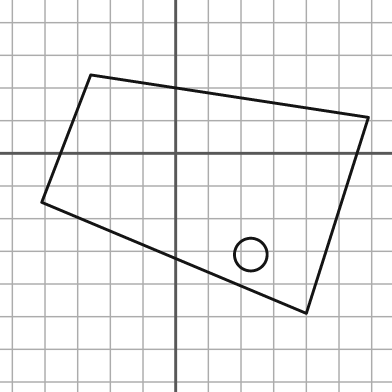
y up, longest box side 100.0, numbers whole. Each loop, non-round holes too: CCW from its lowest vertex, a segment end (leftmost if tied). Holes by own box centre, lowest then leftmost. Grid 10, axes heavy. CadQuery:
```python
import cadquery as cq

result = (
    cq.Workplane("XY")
    .moveTo(40.0, -49.0)
    .lineTo(59.0, 11.0)
    .lineTo(-26.0, 24.0)
    .lineTo(-41.0, -15.0)
    .close()
    .moveTo(23.0, -31.0)
    .circle(5.0)
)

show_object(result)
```